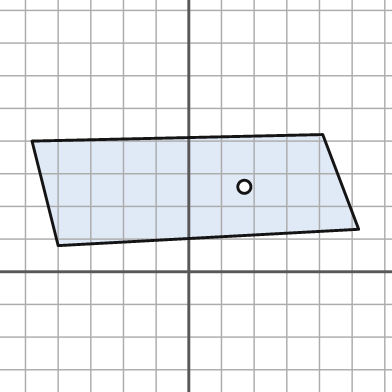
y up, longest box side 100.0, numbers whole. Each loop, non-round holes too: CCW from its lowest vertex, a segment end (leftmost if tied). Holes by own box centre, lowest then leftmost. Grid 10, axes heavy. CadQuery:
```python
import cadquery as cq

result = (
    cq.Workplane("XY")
    .moveTo(-40.0, 8.0)
    .lineTo(52.0, 13.0)
    .lineTo(41.0, 42.0)
    .lineTo(-48.0, 40.0)
    .close()
    .moveTo(17.0, 26.0)
    .circle(2.0)
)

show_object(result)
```